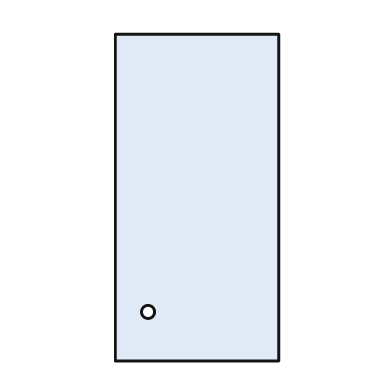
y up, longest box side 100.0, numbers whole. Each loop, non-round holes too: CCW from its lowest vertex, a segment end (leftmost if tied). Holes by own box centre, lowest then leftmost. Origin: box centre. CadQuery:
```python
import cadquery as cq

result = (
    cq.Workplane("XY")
    .moveTo(-25.0, -50.0)
    .lineTo(25.0, -50.0)
    .lineTo(25.0, 50.0)
    .lineTo(-25.0, 50.0)
    .close()
    .moveTo(-15.0, -35.0)
    .circle(2.0)
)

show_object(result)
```